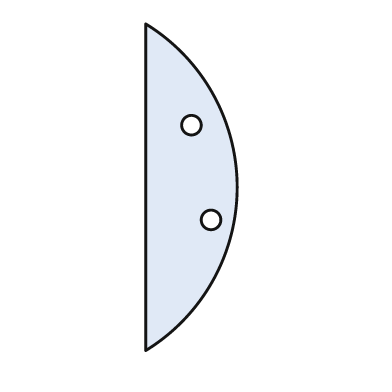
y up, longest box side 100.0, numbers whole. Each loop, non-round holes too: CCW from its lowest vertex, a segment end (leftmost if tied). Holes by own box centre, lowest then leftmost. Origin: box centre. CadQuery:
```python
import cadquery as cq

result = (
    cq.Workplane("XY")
    .moveTo(-14.0, -50.0)
    .threePointArc((14.0, 0.0), (-14.0, 50.0))
    .close()
    .moveTo(6.0, -10.0)
    .circle(3.0)
    .moveTo(0.0, 19.0)
    .circle(3.0)
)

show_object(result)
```